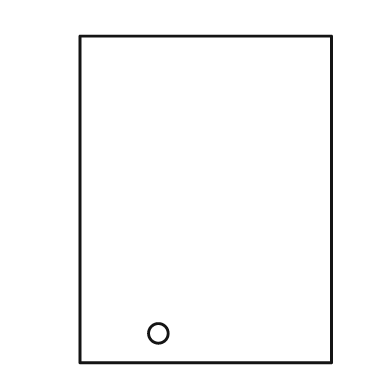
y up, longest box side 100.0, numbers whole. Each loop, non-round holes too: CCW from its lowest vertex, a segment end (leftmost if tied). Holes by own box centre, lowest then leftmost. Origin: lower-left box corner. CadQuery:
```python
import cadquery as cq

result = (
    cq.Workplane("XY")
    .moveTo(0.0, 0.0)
    .lineTo(77.0, 0.0)
    .lineTo(77.0, 100.0)
    .lineTo(0.0, 100.0)
    .close()
    .moveTo(24.0, 9.0)
    .circle(3.0)
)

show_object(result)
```